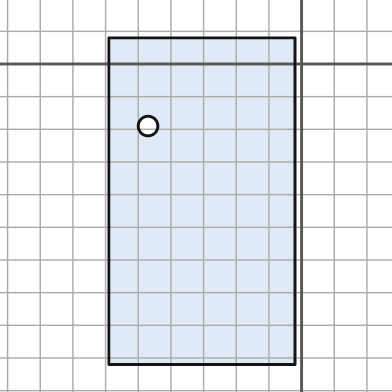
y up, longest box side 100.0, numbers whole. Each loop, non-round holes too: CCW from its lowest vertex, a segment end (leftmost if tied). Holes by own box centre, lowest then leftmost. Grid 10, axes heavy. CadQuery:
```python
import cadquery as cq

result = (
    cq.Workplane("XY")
    .moveTo(-59.0, -92.0)
    .lineTo(-2.0, -92.0)
    .lineTo(-2.0, 8.0)
    .lineTo(-59.0, 8.0)
    .close()
    .moveTo(-47.0, -19.0)
    .circle(3.0)
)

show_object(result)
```